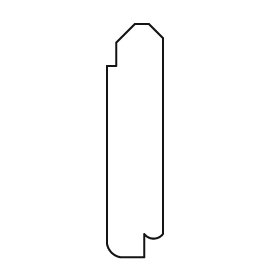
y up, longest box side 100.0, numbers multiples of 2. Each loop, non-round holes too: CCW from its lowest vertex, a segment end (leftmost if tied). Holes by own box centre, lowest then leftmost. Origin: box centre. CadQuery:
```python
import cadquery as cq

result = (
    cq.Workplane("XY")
    .moveTo(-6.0, -50.0)
    .lineTo(4.0, -50.0)
    .lineTo(4.0, -40.0)
    .threePointArc((8.0, -42.0), (12.0, -40.0))
    .lineTo(12.0, 44.0)
    .lineTo(6.0, 50.0)
    .lineTo(0.0, 50.0)
    .lineTo(-8.0, 42.0)
    .lineTo(-8.0, 32.0)
    .lineTo(-12.0, 32.0)
    .lineTo(-12.0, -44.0)
    .threePointArc((-10.0, -48.0), (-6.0, -50.0))
    .close()
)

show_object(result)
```